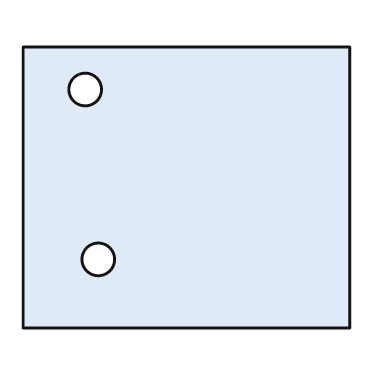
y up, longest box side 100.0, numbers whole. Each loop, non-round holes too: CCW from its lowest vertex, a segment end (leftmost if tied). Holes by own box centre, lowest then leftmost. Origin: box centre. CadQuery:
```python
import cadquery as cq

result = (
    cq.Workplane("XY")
    .moveTo(-50.0, -43.0)
    .lineTo(50.0, -43.0)
    .lineTo(50.0, 43.0)
    .lineTo(-50.0, 43.0)
    .close()
    .moveTo(-27.0, -22.0)
    .circle(5.0)
    .moveTo(-31.0, 30.0)
    .circle(5.0)
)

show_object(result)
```